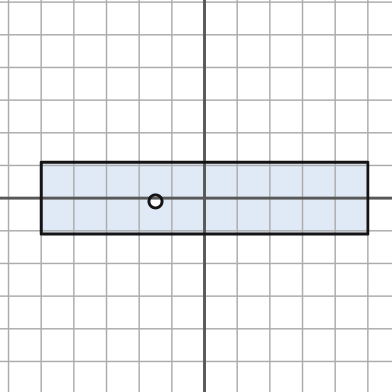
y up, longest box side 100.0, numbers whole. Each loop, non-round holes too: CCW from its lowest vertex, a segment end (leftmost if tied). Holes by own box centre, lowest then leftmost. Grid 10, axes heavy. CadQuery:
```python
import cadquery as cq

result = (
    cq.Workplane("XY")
    .moveTo(-50.0, -11.0)
    .lineTo(50.0, -11.0)
    .lineTo(50.0, 11.0)
    .lineTo(-50.0, 11.0)
    .close()
    .moveTo(-15.0, -1.0)
    .circle(2.0)
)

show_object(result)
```